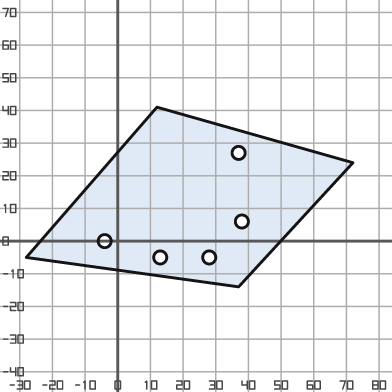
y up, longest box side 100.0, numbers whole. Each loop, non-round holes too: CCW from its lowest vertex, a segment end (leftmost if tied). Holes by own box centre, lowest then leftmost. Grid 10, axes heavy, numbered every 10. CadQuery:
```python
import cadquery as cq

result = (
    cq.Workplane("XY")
    .moveTo(37.0, -14.0)
    .lineTo(72.0, 24.0)
    .lineTo(12.0, 41.0)
    .lineTo(-28.0, -5.0)
    .close()
    .moveTo(13.0, -5.0)
    .circle(2.0)
    .moveTo(28.0, -5.0)
    .circle(2.0)
    .moveTo(-4.0, 0.0)
    .circle(2.0)
    .moveTo(38.0, 6.0)
    .circle(2.0)
    .moveTo(37.0, 27.0)
    .circle(2.0)
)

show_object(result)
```